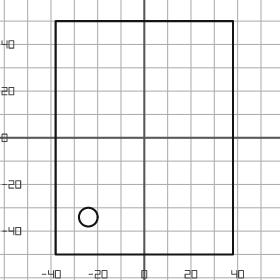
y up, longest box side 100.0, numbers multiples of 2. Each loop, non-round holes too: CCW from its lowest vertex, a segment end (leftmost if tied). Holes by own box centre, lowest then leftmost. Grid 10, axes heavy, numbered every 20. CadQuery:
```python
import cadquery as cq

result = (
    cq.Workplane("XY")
    .moveTo(-38.0, -50.0)
    .lineTo(38.0, -50.0)
    .lineTo(38.0, 50.0)
    .lineTo(-38.0, 50.0)
    .close()
    .moveTo(-24.0, -34.0)
    .circle(4.0)
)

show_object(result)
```